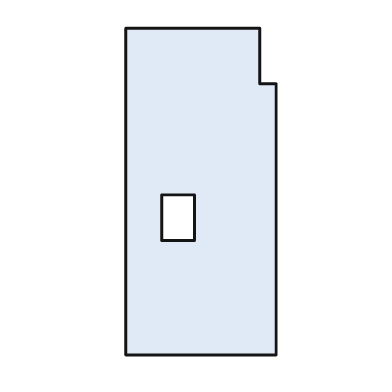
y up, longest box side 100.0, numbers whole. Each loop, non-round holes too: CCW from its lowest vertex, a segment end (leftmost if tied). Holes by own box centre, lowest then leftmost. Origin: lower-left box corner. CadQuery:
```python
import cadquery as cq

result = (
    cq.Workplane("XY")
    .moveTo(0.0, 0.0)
    .lineTo(46.0, 0.0)
    .lineTo(46.0, 83.0)
    .lineTo(41.0, 83.0)
    .lineTo(41.0, 100.0)
    .lineTo(0.0, 100.0)
    .close()
    .moveTo(11.0, 35.0)
    .lineTo(21.0, 35.0)
    .lineTo(21.0, 49.0)
    .lineTo(11.0, 49.0)
    .close()
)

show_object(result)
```